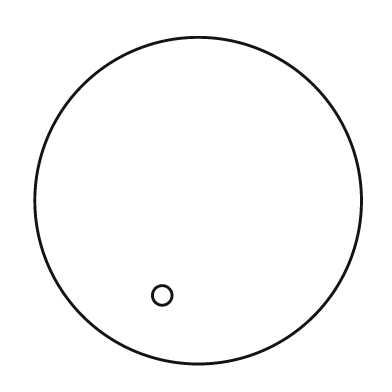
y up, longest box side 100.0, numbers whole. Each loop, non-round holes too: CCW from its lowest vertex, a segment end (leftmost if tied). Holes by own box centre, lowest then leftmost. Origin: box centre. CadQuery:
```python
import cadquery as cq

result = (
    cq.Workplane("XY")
    .moveTo(0.0, 0.0)
    .circle(50.0)
    .moveTo(-11.0, -29.0)
    .circle(3.0)
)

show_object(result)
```